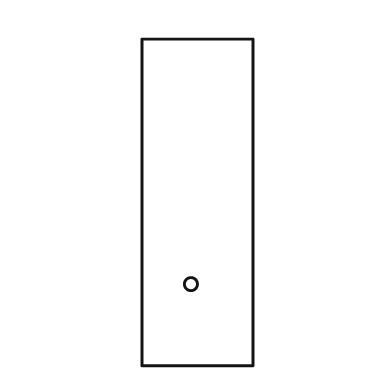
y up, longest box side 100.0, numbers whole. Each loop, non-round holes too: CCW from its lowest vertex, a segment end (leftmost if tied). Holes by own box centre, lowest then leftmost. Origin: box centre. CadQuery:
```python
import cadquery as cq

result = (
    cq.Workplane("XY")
    .moveTo(-17.0, -50.0)
    .lineTo(17.0, -50.0)
    .lineTo(17.0, 50.0)
    .lineTo(-17.0, 50.0)
    .close()
    .moveTo(-2.0, -25.0)
    .circle(2.0)
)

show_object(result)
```